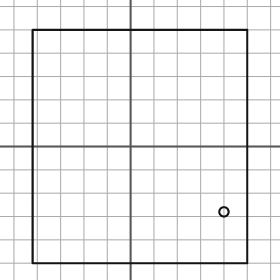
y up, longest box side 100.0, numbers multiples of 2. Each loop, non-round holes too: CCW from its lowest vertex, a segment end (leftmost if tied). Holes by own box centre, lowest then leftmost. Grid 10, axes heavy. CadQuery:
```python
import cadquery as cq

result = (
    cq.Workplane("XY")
    .moveTo(-42.0, -50.0)
    .lineTo(50.0, -50.0)
    .lineTo(50.0, 50.0)
    .lineTo(-42.0, 50.0)
    .close()
    .moveTo(40.0, -28.0)
    .circle(2.0)
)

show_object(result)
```